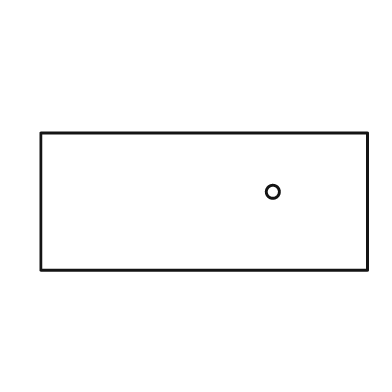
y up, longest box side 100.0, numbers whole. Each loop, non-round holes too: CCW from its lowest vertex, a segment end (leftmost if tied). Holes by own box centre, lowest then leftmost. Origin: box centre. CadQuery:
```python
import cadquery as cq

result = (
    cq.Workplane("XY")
    .moveTo(-50.0, -21.0)
    .lineTo(50.0, -21.0)
    .lineTo(50.0, 21.0)
    .lineTo(-50.0, 21.0)
    .close()
    .moveTo(21.0, 3.0)
    .circle(2.0)
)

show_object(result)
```